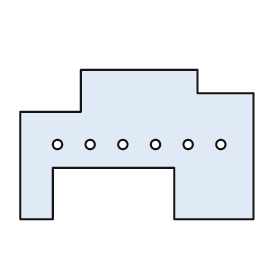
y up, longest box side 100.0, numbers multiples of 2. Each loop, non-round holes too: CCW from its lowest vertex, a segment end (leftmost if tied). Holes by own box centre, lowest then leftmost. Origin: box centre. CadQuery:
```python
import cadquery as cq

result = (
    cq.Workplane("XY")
    .moveTo(-50.0, -32.0)
    .lineTo(-36.0, -32.0)
    .lineTo(-36.0, -10.0)
    .lineTo(16.0, -10.0)
    .lineTo(16.0, -32.0)
    .lineTo(50.0, -32.0)
    .lineTo(50.0, 22.0)
    .lineTo(26.0, 22.0)
    .lineTo(26.0, 32.0)
    .lineTo(-24.0, 32.0)
    .lineTo(-24.0, 14.0)
    .lineTo(-50.0, 14.0)
    .close()
    .moveTo(-34.0, 0.0)
    .circle(2.0)
    .moveTo(-20.0, 0.0)
    .circle(2.0)
    .moveTo(-6.0, 0.0)
    .circle(2.0)
    .moveTo(8.0, 0.0)
    .circle(2.0)
    .moveTo(22.0, 0.0)
    .circle(2.0)
    .moveTo(36.0, 0.0)
    .circle(2.0)
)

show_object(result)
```